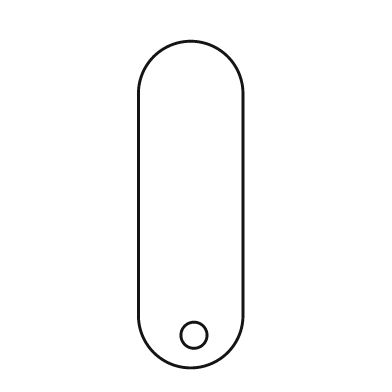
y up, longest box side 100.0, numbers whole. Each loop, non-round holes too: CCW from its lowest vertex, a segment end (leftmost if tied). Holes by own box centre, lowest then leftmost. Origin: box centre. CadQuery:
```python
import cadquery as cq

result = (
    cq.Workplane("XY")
    .moveTo(-16.0, -34.0)
    .threePointArc((0.0, -50.0), (16.0, -34.0))
    .lineTo(16.0, 34.0)
    .threePointArc((0.0, 50.0), (-16.0, 34.0))
    .close()
    .moveTo(1.0, -40.0)
    .circle(4.0)
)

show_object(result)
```